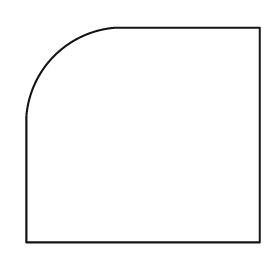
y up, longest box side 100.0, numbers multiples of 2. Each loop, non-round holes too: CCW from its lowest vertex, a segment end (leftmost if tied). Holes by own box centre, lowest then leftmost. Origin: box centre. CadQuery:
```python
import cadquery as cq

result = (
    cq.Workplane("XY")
    .moveTo(-50.0, -46.0)
    .lineTo(50.0, -46.0)
    .lineTo(50.0, 46.0)
    .lineTo(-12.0, 46.0)
    .threePointArc((-38.0, 34.0), (-50.0, 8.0))
    .close()
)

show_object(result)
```